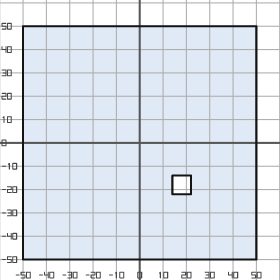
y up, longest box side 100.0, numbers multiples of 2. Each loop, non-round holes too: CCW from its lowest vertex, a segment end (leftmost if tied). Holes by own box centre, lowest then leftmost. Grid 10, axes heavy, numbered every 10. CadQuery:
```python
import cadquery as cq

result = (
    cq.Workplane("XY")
    .moveTo(-50.0, -50.0)
    .lineTo(50.0, -50.0)
    .lineTo(50.0, 50.0)
    .lineTo(-50.0, 50.0)
    .close()
    .moveTo(14.0, -22.0)
    .lineTo(22.0, -22.0)
    .lineTo(22.0, -14.0)
    .lineTo(14.0, -14.0)
    .close()
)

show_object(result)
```